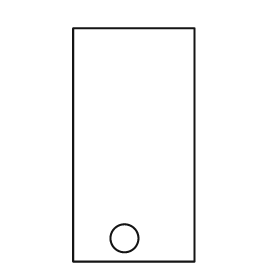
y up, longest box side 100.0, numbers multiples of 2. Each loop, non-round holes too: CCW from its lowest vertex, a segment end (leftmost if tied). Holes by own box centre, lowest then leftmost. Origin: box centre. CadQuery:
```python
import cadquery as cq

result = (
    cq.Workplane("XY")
    .moveTo(-26.0, -50.0)
    .lineTo(26.0, -50.0)
    .lineTo(26.0, 50.0)
    .lineTo(-26.0, 50.0)
    .close()
    .moveTo(-4.0, -40.0)
    .circle(6.0)
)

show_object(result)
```